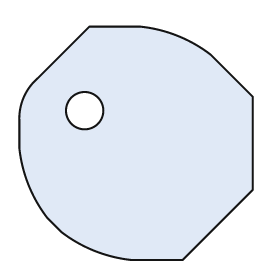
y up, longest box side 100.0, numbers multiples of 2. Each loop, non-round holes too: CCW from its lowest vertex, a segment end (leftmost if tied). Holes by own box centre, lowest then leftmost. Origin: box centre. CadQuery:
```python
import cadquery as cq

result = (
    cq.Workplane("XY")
    .moveTo(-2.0, -50.0)
    .lineTo(20.0, -50.0)
    .lineTo(50.0, -20.0)
    .lineTo(50.0, 20.0)
    .lineTo(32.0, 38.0)
    .threePointArc((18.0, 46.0), (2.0, 50.0))
    .lineTo(-20.0, 50.0)
    .lineTo(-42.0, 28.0)
    .threePointArc((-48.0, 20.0), (-50.0, 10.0))
    .lineTo(-50.0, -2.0)
    .threePointArc((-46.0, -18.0), (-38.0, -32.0))
    .lineTo(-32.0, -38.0)
    .threePointArc((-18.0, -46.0), (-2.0, -50.0))
    .close()
    .moveTo(-22.0, 14.0)
    .circle(8.0)
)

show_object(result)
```